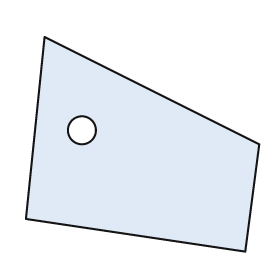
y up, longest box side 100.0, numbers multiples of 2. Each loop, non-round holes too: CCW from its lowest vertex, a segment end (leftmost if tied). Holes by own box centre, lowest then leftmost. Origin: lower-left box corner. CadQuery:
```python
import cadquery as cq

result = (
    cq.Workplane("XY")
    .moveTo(94.0, 0.0)
    .lineTo(100.0, 46.0)
    .lineTo(8.0, 92.0)
    .lineTo(0.0, 14.0)
    .close()
    .moveTo(24.0, 52.0)
    .circle(6.0)
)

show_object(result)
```